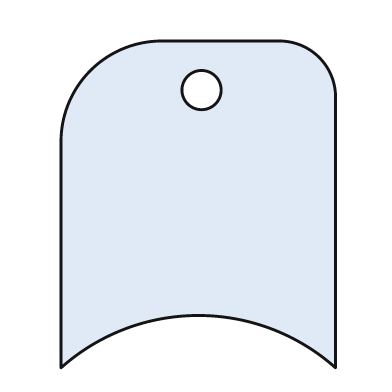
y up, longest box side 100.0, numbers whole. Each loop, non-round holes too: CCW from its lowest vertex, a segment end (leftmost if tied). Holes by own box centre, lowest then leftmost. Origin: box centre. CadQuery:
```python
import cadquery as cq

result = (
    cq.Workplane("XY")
    .moveTo(-42.0, -50.0)
    .threePointArc((0.0, -34.0), (42.0, -50.0))
    .lineTo(42.0, 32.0)
    .threePointArc((37.0, 45.0), (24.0, 50.0))
    .lineTo(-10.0, 50.0)
    .threePointArc((-33.0, 41.0), (-42.0, 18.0))
    .close()
    .moveTo(1.0, 35.0)
    .circle(6.0)
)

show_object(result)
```